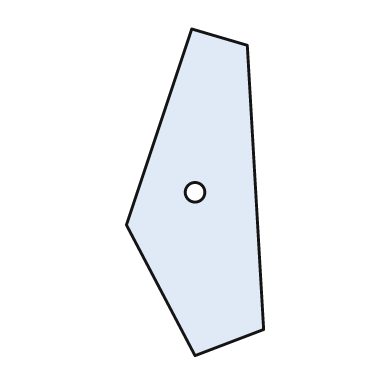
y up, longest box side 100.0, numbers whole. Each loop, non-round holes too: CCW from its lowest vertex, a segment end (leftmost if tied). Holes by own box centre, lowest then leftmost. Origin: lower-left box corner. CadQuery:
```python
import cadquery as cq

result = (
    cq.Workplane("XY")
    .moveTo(21.0, 0.0)
    .lineTo(42.0, 8.0)
    .lineTo(37.0, 95.0)
    .lineTo(20.0, 100.0)
    .lineTo(0.0, 40.0)
    .close()
    .moveTo(21.0, 50.0)
    .circle(3.0)
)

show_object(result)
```